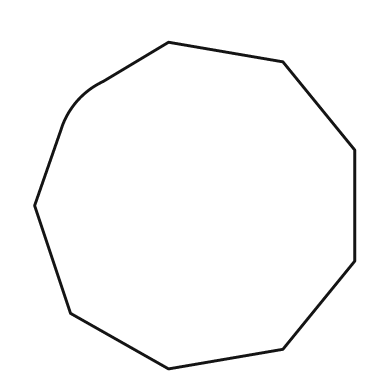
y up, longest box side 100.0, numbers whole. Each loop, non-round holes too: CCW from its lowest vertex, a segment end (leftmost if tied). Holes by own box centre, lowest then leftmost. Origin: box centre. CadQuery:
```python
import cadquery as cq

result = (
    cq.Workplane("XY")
    .moveTo(-8.0, -50.0)
    .lineTo(27.0, -44.0)
    .lineTo(49.0, -17.0)
    .lineTo(49.0, 17.0)
    .lineTo(27.0, 44.0)
    .lineTo(-8.0, 50.0)
    .lineTo(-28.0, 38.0)
    .threePointArc((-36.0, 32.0), (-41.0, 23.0))
    .lineTo(-49.0, 0.0)
    .lineTo(-38.0, -33.0)
    .close()
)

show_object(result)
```